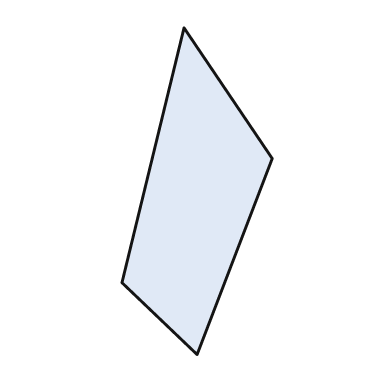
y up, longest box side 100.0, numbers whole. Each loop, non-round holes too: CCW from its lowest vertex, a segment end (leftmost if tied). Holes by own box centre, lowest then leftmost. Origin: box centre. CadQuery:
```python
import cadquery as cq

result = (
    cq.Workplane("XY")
    .moveTo(0.0, -50.0)
    .lineTo(23.0, 10.0)
    .lineTo(-4.0, 50.0)
    .lineTo(-23.0, -28.0)
    .close()
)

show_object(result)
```